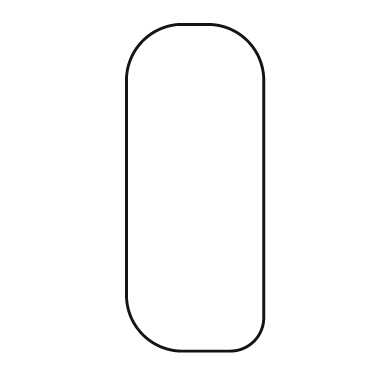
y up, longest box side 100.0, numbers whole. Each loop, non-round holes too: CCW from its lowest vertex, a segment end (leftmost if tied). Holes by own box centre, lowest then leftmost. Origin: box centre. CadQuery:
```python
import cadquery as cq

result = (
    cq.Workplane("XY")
    .moveTo(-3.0, -50.0)
    .lineTo(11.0, -50.0)
    .threePointArc((18.0, -47.0), (21.0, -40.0))
    .lineTo(21.0, 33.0)
    .threePointArc((16.0, 45.0), (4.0, 50.0))
    .lineTo(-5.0, 50.0)
    .threePointArc((-16.0, 45.0), (-21.0, 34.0))
    .lineTo(-21.0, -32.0)
    .threePointArc((-16.0, -45.0), (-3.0, -50.0))
    .close()
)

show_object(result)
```